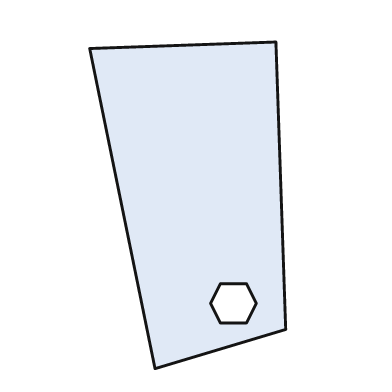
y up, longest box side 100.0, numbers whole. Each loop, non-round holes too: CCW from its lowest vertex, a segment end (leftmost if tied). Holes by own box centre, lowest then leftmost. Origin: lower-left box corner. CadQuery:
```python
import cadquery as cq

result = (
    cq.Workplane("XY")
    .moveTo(20.0, 0.0)
    .lineTo(60.0, 12.0)
    .lineTo(57.0, 100.0)
    .lineTo(0.0, 98.0)
    .close()
    .moveTo(40.0, 14.0)
    .lineTo(48.0, 14.0)
    .lineTo(51.0, 20.0)
    .lineTo(48.0, 26.0)
    .lineTo(40.0, 26.0)
    .lineTo(37.0, 20.0)
    .close()
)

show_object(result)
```